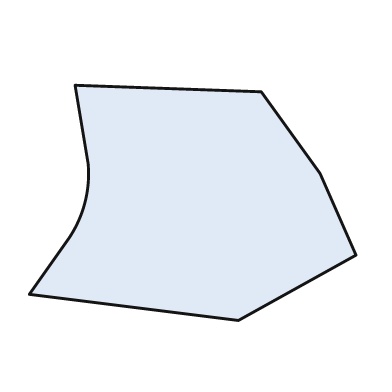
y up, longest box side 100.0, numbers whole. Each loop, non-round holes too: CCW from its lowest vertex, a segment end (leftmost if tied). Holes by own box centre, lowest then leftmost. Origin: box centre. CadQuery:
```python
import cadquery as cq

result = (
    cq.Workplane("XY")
    .moveTo(14.0, -36.0)
    .lineTo(50.0, -16.0)
    .lineTo(39.0, 9.0)
    .lineTo(21.0, 34.0)
    .lineTo(-36.0, 36.0)
    .lineTo(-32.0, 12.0)
    .threePointArc((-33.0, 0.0), (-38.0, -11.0))
    .lineTo(-50.0, -28.0)
    .close()
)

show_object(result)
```